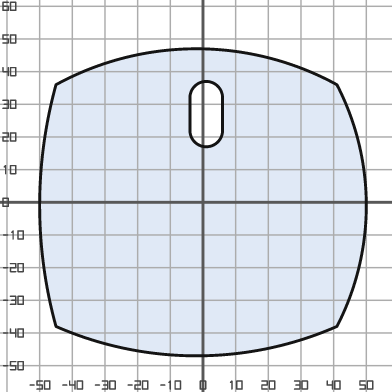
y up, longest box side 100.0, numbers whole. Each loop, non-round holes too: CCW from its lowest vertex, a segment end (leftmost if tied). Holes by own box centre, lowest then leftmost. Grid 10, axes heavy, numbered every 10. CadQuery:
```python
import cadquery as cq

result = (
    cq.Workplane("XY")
    .moveTo(-45.0, -38.0)
    .threePointArc((-2.0, -47.0), (41.0, -38.0))
    .threePointArc((50.0, -1.0), (41.0, 36.0))
    .threePointArc((-2.0, 47.0), (-45.0, 36.0))
    .threePointArc((-50.0, -1.0), (-45.0, -38.0))
    .close()
    .moveTo(-4.0, 22.0)
    .threePointArc((1.0, 17.0), (6.0, 22.0))
    .lineTo(6.0, 32.0)
    .threePointArc((1.0, 37.0), (-4.0, 32.0))
    .close()
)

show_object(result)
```